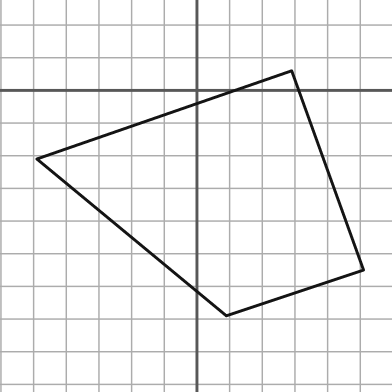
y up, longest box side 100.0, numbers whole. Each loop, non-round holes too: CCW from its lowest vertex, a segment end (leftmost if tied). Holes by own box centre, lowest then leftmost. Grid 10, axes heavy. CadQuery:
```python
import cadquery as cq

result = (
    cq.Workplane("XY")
    .moveTo(9.0, -69.0)
    .lineTo(51.0, -55.0)
    .lineTo(29.0, 6.0)
    .lineTo(-49.0, -21.0)
    .close()
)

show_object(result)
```